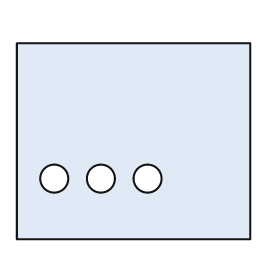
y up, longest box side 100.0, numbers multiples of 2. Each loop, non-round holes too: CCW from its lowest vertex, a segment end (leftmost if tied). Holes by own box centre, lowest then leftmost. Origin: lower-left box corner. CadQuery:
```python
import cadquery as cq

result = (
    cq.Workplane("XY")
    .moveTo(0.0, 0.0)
    .lineTo(100.0, 0.0)
    .lineTo(100.0, 84.0)
    .lineTo(0.0, 84.0)
    .close()
    .moveTo(16.0, 26.0)
    .circle(6.0)
    .moveTo(36.0, 26.0)
    .circle(6.0)
    .moveTo(56.0, 26.0)
    .circle(6.0)
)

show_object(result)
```